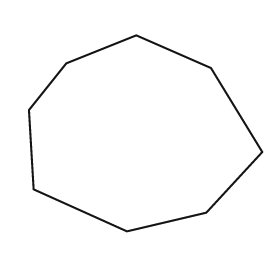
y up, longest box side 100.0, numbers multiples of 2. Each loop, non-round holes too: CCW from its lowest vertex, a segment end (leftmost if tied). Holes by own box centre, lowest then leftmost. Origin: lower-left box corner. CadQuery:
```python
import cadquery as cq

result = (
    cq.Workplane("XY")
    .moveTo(42.0, 0.0)
    .lineTo(76.0, 8.0)
    .lineTo(100.0, 34.0)
    .lineTo(78.0, 70.0)
    .lineTo(46.0, 84.0)
    .lineTo(16.0, 72.0)
    .lineTo(0.0, 52.0)
    .lineTo(2.0, 18.0)
    .close()
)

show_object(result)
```